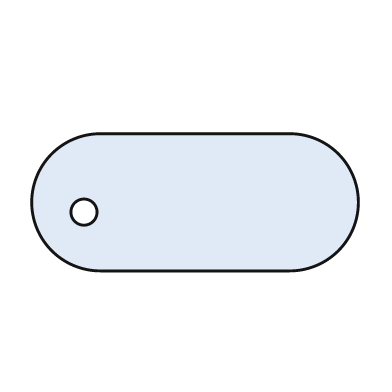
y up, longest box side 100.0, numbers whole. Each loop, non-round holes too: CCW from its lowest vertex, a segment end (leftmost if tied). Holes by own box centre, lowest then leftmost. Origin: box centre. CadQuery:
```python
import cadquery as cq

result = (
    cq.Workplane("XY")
    .moveTo(-29.0, -21.0)
    .lineTo(29.0, -21.0)
    .threePointArc((50.0, 0.0), (29.0, 21.0))
    .lineTo(-29.0, 21.0)
    .threePointArc((-50.0, 0.0), (-29.0, -21.0))
    .close()
    .moveTo(-34.0, -3.0)
    .circle(4.0)
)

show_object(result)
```